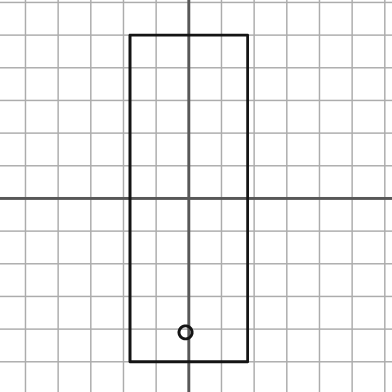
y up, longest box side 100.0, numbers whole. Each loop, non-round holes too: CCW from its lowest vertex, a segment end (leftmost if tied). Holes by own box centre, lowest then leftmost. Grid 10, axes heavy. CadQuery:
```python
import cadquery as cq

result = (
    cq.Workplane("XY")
    .moveTo(-18.0, -50.0)
    .lineTo(18.0, -50.0)
    .lineTo(18.0, 50.0)
    .lineTo(-18.0, 50.0)
    .close()
    .moveTo(-1.0, -41.0)
    .circle(2.0)
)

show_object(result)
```